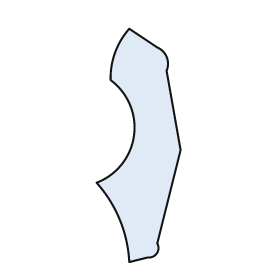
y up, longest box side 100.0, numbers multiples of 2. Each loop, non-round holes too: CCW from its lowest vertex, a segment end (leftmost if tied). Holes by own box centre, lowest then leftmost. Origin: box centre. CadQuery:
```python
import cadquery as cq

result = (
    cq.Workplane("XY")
    .moveTo(-4.0, -50.0)
    .lineTo(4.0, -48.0)
    .threePointArc((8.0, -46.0), (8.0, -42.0))
    .lineTo(18.0, -2.0)
    .lineTo(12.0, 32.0)
    .threePointArc((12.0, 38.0), (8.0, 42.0))
    .lineTo(-4.0, 50.0)
    .threePointArc((-10.0, 40.0), (-12.0, 28.0))
    .threePointArc((-2.0, 4.0), (-18.0, -16.0))
    .threePointArc((-8.0, -32.0), (-4.0, -50.0))
    .close()
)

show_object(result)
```